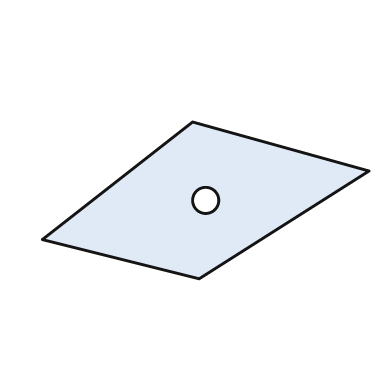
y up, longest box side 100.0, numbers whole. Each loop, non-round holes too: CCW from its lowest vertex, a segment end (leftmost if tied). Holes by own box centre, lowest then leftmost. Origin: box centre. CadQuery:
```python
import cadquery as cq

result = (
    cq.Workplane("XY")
    .moveTo(-2.0, -24.0)
    .lineTo(50.0, 9.0)
    .lineTo(-4.0, 24.0)
    .lineTo(-50.0, -12.0)
    .close()
    .moveTo(0.0, 0.0)
    .circle(4.0)
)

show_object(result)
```